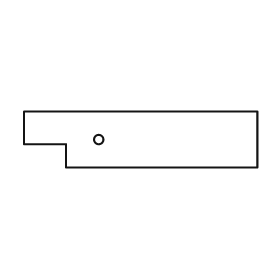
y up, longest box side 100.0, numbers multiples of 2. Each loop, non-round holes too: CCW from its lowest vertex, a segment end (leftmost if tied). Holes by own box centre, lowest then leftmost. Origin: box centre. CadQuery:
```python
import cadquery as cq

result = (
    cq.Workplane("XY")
    .moveTo(-32.0, -12.0)
    .lineTo(50.0, -12.0)
    .lineTo(50.0, 12.0)
    .lineTo(-50.0, 12.0)
    .lineTo(-50.0, -2.0)
    .lineTo(-32.0, -2.0)
    .close()
    .moveTo(-18.0, 0.0)
    .circle(2.0)
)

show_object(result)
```